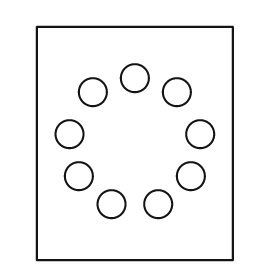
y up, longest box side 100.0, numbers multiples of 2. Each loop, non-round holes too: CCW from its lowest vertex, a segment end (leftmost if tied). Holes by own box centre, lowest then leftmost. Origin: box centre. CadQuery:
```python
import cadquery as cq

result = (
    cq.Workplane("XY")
    .moveTo(-42.0, -50.0)
    .lineTo(42.0, -50.0)
    .lineTo(42.0, 50.0)
    .lineTo(-42.0, 50.0)
    .close()
    .moveTo(-10.0, -26.0)
    .circle(6.0)
    .moveTo(10.0, -26.0)
    .circle(6.0)
    .moveTo(-24.0, -14.0)
    .circle(6.0)
    .moveTo(24.0, -14.0)
    .circle(6.0)
    .moveTo(-28.0, 4.0)
    .circle(6.0)
    .moveTo(28.0, 4.0)
    .circle(6.0)
    .moveTo(-18.0, 22.0)
    .circle(6.0)
    .moveTo(18.0, 22.0)
    .circle(6.0)
    .moveTo(0.0, 28.0)
    .circle(6.0)
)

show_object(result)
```